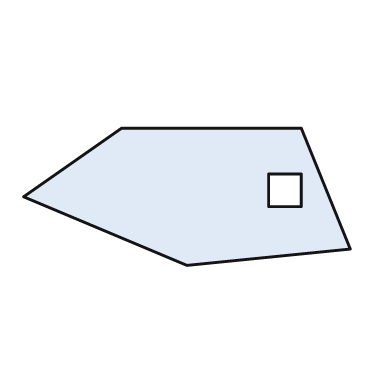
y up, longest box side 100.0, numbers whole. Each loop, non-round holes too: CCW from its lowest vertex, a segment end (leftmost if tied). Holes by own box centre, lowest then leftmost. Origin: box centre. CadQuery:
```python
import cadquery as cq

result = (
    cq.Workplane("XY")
    .moveTo(0.0, -21.0)
    .lineTo(50.0, -16.0)
    .lineTo(35.0, 21.0)
    .lineTo(-20.0, 21.0)
    .lineTo(-50.0, 0.0)
    .close()
    .moveTo(25.0, -3.0)
    .lineTo(35.0, -3.0)
    .lineTo(35.0, 7.0)
    .lineTo(25.0, 7.0)
    .close()
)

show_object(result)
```